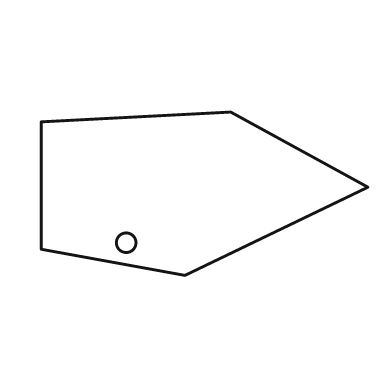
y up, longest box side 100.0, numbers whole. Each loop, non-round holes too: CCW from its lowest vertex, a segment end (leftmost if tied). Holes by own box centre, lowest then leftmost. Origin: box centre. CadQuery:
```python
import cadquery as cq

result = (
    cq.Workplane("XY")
    .moveTo(-6.0, -25.0)
    .lineTo(50.0, 2.0)
    .lineTo(8.0, 25.0)
    .lineTo(-50.0, 22.0)
    .lineTo(-50.0, -17.0)
    .close()
    .moveTo(-24.0, -15.0)
    .circle(3.0)
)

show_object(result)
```